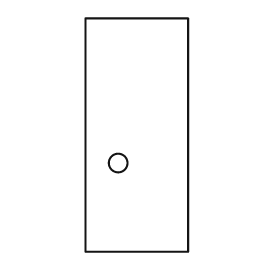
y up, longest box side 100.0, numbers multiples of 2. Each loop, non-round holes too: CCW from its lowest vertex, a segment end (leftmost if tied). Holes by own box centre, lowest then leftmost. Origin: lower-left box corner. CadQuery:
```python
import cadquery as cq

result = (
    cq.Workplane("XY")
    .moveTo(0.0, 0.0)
    .lineTo(44.0, 0.0)
    .lineTo(44.0, 100.0)
    .lineTo(0.0, 100.0)
    .close()
    .moveTo(14.0, 38.0)
    .circle(4.0)
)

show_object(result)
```